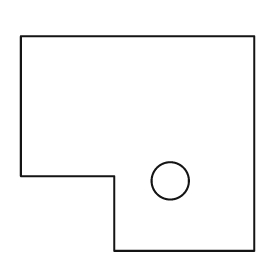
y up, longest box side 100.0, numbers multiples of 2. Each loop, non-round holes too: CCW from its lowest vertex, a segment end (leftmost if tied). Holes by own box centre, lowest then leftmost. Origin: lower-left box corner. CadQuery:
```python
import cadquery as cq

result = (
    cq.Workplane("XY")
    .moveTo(40.0, 0.0)
    .lineTo(100.0, 0.0)
    .lineTo(100.0, 92.0)
    .lineTo(0.0, 92.0)
    .lineTo(0.0, 32.0)
    .lineTo(40.0, 32.0)
    .close()
    .moveTo(64.0, 30.0)
    .circle(8.0)
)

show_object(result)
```